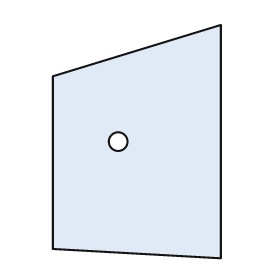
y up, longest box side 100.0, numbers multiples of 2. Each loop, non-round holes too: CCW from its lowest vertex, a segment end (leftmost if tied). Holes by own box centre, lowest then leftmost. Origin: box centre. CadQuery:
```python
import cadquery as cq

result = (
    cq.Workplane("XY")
    .moveTo(36.0, -50.0)
    .lineTo(36.0, 50.0)
    .lineTo(-36.0, 28.0)
    .lineTo(-36.0, -46.0)
    .close()
    .moveTo(-8.0, 0.0)
    .circle(4.0)
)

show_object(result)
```